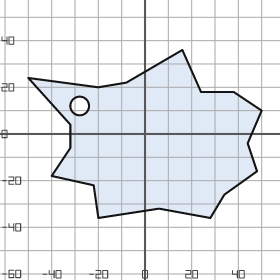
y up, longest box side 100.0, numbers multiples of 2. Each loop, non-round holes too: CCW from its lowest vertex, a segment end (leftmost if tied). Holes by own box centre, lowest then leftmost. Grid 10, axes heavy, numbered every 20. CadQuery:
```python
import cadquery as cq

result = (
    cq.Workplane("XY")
    .moveTo(-20.0, -36.0)
    .lineTo(6.0, -32.0)
    .lineTo(28.0, -36.0)
    .lineTo(34.0, -26.0)
    .lineTo(48.0, -16.0)
    .lineTo(44.0, -4.0)
    .lineTo(50.0, 10.0)
    .lineTo(38.0, 18.0)
    .lineTo(24.0, 18.0)
    .lineTo(16.0, 36.0)
    .lineTo(-8.0, 22.0)
    .lineTo(-20.0, 20.0)
    .lineTo(-50.0, 24.0)
    .lineTo(-32.0, 4.0)
    .lineTo(-32.0, -6.0)
    .lineTo(-40.0, -18.0)
    .lineTo(-22.0, -22.0)
    .close()
    .moveTo(-28.0, 12.0)
    .circle(4.0)
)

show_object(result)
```